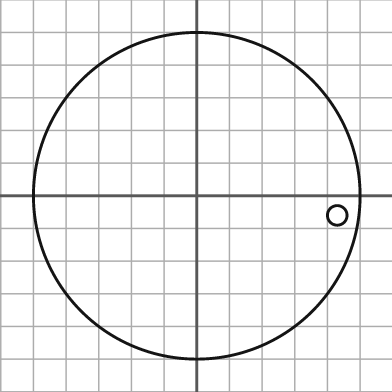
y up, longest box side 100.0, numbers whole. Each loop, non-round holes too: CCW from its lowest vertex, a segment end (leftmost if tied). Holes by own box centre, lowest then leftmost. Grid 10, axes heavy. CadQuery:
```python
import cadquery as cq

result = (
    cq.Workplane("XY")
    .moveTo(0.0, 0.0)
    .circle(50.0)
    .moveTo(43.0, -6.0)
    .circle(3.0)
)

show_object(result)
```